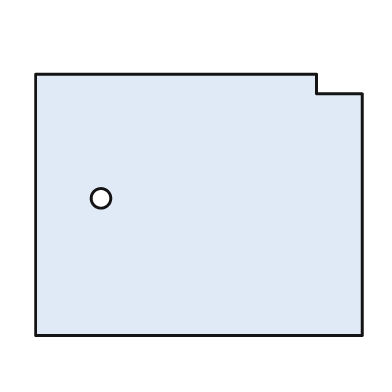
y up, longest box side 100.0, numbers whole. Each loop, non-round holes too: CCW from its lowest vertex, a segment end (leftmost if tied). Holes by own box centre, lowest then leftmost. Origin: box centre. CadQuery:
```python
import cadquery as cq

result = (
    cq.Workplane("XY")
    .moveTo(-50.0, -40.0)
    .lineTo(50.0, -40.0)
    .lineTo(50.0, 34.0)
    .lineTo(36.0, 34.0)
    .lineTo(36.0, 40.0)
    .lineTo(-50.0, 40.0)
    .close()
    .moveTo(-30.0, 2.0)
    .circle(3.0)
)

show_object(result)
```